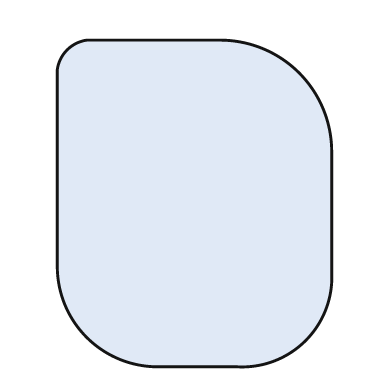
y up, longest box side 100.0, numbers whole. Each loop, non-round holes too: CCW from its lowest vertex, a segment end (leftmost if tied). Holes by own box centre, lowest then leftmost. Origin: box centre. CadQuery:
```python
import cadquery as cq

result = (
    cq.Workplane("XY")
    .moveTo(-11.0, -50.0)
    .lineTo(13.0, -50.0)
    .threePointArc((34.0, -42.0), (42.0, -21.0))
    .lineTo(42.0, 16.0)
    .threePointArc((32.0, 40.0), (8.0, 50.0))
    .lineTo(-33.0, 50.0)
    .threePointArc((-39.0, 47.0), (-42.0, 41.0))
    .lineTo(-42.0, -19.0)
    .threePointArc((-33.0, -41.0), (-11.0, -50.0))
    .close()
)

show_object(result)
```